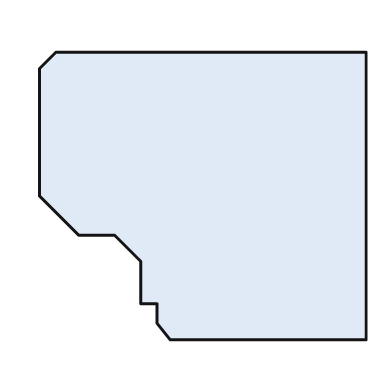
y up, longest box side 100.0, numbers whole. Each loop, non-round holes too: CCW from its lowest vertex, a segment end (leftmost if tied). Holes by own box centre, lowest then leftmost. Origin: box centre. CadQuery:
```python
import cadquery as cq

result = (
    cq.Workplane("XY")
    .moveTo(-10.0, -44.0)
    .lineTo(50.0, -44.0)
    .lineTo(50.0, 44.0)
    .lineTo(-45.0, 44.0)
    .lineTo(-50.0, 39.0)
    .lineTo(-50.0, 0.0)
    .lineTo(-38.0, -12.0)
    .lineTo(-27.0, -12.0)
    .lineTo(-19.0, -20.0)
    .lineTo(-19.0, -33.0)
    .lineTo(-14.0, -33.0)
    .lineTo(-14.0, -39.0)
    .close()
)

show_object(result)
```